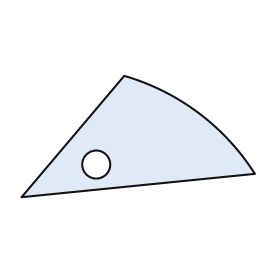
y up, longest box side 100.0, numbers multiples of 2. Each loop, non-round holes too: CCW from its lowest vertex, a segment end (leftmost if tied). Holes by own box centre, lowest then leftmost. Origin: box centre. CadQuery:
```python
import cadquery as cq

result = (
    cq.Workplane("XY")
    .moveTo(-50.0, -26.0)
    .lineTo(50.0, -16.0)
    .threePointArc((26.0, 10.0), (-6.0, 26.0))
    .close()
    .moveTo(-18.0, -12.0)
    .circle(6.0)
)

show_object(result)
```